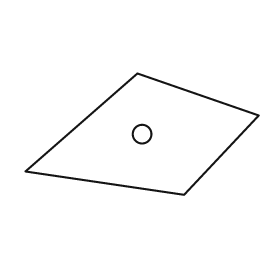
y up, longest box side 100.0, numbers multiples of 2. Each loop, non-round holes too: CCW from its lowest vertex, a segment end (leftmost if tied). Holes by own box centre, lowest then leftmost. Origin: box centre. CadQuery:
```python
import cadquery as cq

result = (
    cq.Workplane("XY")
    .moveTo(18.0, -26.0)
    .lineTo(50.0, 8.0)
    .lineTo(-2.0, 26.0)
    .lineTo(-50.0, -16.0)
    .close()
    .moveTo(0.0, 0.0)
    .circle(4.0)
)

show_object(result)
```